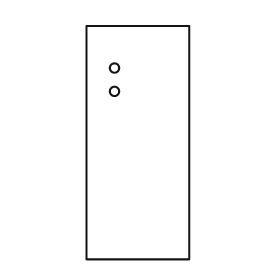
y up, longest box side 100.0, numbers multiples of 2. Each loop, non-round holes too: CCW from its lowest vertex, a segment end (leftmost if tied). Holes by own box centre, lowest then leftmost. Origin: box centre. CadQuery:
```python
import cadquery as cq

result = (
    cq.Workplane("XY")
    .moveTo(-22.0, -50.0)
    .lineTo(22.0, -50.0)
    .lineTo(22.0, 50.0)
    .lineTo(-22.0, 50.0)
    .close()
    .moveTo(-10.0, 22.0)
    .circle(2.0)
    .moveTo(-10.0, 32.0)
    .circle(2.0)
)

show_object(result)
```